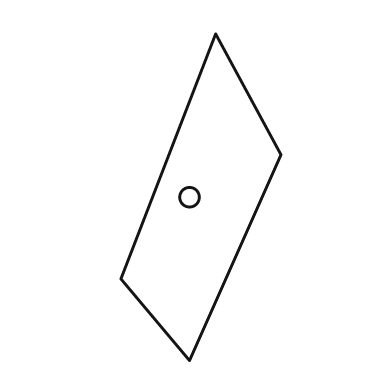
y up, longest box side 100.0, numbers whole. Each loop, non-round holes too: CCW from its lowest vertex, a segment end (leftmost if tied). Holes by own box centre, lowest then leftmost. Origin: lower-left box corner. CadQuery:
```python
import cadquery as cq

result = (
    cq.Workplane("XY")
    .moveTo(21.0, 0.0)
    .lineTo(49.0, 63.0)
    .lineTo(29.0, 100.0)
    .lineTo(0.0, 25.0)
    .close()
    .moveTo(21.0, 50.0)
    .circle(3.0)
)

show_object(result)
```